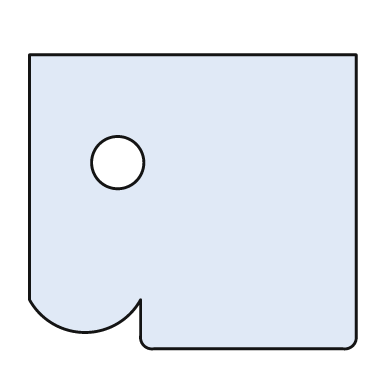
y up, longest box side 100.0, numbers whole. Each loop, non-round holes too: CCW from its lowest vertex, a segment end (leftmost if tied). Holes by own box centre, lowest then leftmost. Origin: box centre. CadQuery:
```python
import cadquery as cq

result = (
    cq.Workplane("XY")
    .moveTo(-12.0, -45.0)
    .lineTo(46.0, -45.0)
    .threePointArc((49.0, -44.0), (50.0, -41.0))
    .lineTo(50.0, 45.0)
    .lineTo(-50.0, 45.0)
    .lineTo(-50.0, -30.0)
    .threePointArc((-33.0, -40.0), (-16.0, -30.0))
    .lineTo(-16.0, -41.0)
    .threePointArc((-15.0, -44.0), (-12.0, -45.0))
    .close()
    .moveTo(-23.0, 12.0)
    .circle(8.0)
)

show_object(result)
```